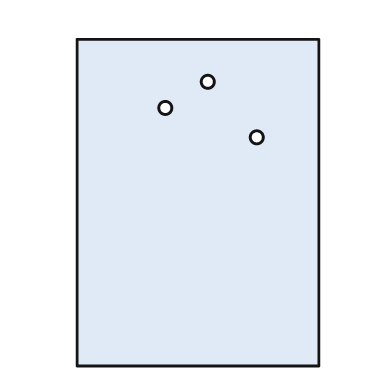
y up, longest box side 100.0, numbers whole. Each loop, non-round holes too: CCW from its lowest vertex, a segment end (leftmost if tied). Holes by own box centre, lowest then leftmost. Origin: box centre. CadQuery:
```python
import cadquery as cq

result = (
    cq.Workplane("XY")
    .moveTo(-37.0, -50.0)
    .lineTo(37.0, -50.0)
    .lineTo(37.0, 50.0)
    .lineTo(-37.0, 50.0)
    .close()
    .moveTo(18.0, 20.0)
    .circle(2.0)
    .moveTo(-10.0, 29.0)
    .circle(2.0)
    .moveTo(3.0, 37.0)
    .circle(2.0)
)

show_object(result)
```